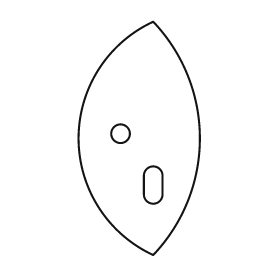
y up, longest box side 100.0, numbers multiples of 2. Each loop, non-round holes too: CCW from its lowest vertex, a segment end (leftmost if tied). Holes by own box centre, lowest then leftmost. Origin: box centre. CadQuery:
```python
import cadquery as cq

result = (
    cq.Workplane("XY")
    .moveTo(6.0, -50.0)
    .threePointArc((26.0, 0.0), (6.0, 50.0))
    .threePointArc((-26.0, 0.0), (6.0, -50.0))
    .close()
    .moveTo(2.0, -24.0)
    .threePointArc((6.0, -28.0), (10.0, -24.0))
    .lineTo(10.0, -16.0)
    .threePointArc((6.0, -12.0), (2.0, -16.0))
    .close()
    .moveTo(-8.0, 2.0)
    .circle(4.0)
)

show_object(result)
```